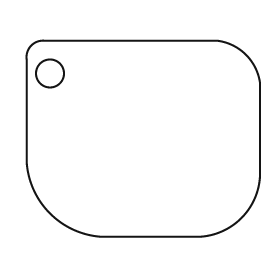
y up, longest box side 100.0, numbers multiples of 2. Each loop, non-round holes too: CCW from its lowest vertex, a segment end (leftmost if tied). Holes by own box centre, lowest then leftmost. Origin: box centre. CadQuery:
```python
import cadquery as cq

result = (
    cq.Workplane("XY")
    .moveTo(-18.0, -42.0)
    .lineTo(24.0, -42.0)
    .threePointArc((42.0, -34.0), (50.0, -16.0))
    .lineTo(50.0, 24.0)
    .threePointArc((44.0, 36.0), (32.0, 42.0))
    .lineTo(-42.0, 42.0)
    .threePointArc((-48.0, 40.0), (-50.0, 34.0))
    .lineTo(-50.0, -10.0)
    .threePointArc((-40.0, -32.0), (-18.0, -42.0))
    .close()
    .moveTo(-40.0, 28.0)
    .circle(6.0)
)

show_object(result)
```